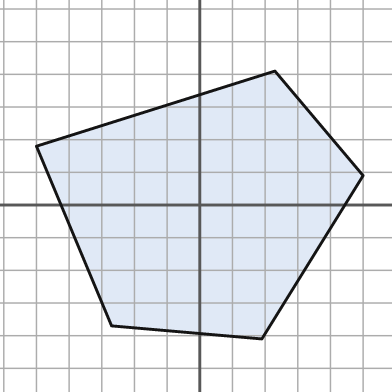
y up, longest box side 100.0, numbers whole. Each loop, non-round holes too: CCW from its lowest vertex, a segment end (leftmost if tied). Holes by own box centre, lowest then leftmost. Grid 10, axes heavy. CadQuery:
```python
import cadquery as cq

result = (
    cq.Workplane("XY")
    .moveTo(19.0, -41.0)
    .lineTo(50.0, 9.0)
    .lineTo(23.0, 41.0)
    .lineTo(-50.0, 18.0)
    .lineTo(-27.0, -37.0)
    .close()
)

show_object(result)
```